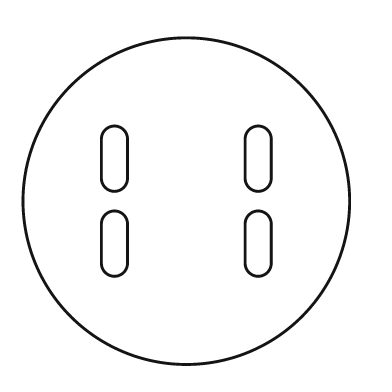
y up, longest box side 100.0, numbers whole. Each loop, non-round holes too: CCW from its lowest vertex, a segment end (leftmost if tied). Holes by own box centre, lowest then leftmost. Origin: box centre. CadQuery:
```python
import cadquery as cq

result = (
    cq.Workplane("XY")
    .moveTo(0.0, 0.0)
    .circle(50.0)
    .moveTo(-26.0, -19.0)
    .threePointArc((-22.0, -23.0), (-18.0, -19.0))
    .lineTo(-18.0, -7.0)
    .threePointArc((-22.0, -3.0), (-26.0, -7.0))
    .close()
    .moveTo(18.0, -19.0)
    .threePointArc((22.0, -23.0), (26.0, -19.0))
    .lineTo(26.0, -7.0)
    .threePointArc((22.0, -3.0), (18.0, -7.0))
    .close()
    .moveTo(-26.0, 7.0)
    .threePointArc((-22.0, 3.0), (-18.0, 7.0))
    .lineTo(-18.0, 19.0)
    .threePointArc((-22.0, 23.0), (-26.0, 19.0))
    .close()
    .moveTo(18.0, 7.0)
    .threePointArc((22.0, 3.0), (26.0, 7.0))
    .lineTo(26.0, 19.0)
    .threePointArc((22.0, 23.0), (18.0, 19.0))
    .close()
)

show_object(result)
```